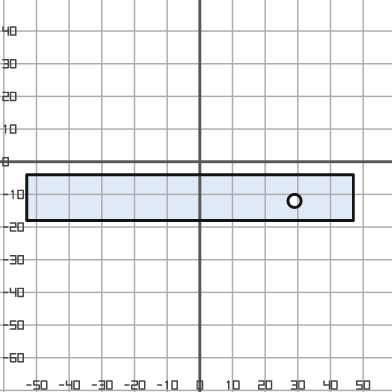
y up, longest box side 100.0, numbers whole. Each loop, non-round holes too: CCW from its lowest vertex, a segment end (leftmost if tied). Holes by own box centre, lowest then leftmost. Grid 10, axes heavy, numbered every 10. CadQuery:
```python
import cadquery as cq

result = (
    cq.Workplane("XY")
    .moveTo(-53.0, -18.0)
    .lineTo(47.0, -18.0)
    .lineTo(47.0, -4.0)
    .lineTo(-53.0, -4.0)
    .close()
    .moveTo(29.0, -12.0)
    .circle(2.0)
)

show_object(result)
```